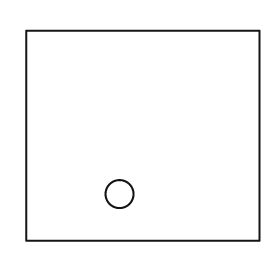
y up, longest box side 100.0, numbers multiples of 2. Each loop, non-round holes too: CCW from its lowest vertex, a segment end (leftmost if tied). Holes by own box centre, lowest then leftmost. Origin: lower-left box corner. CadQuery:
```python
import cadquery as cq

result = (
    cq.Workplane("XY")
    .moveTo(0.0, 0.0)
    .lineTo(100.0, 0.0)
    .lineTo(100.0, 90.0)
    .lineTo(0.0, 90.0)
    .close()
    .moveTo(40.0, 20.0)
    .circle(6.0)
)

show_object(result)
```